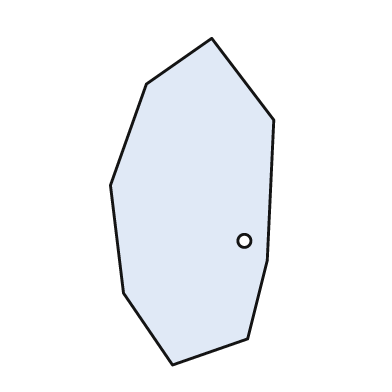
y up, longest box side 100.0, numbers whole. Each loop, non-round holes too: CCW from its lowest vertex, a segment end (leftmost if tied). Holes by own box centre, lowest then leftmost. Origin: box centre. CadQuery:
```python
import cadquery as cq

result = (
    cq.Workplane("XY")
    .moveTo(-6.0, -50.0)
    .lineTo(17.0, -42.0)
    .lineTo(23.0, -18.0)
    .lineTo(25.0, 25.0)
    .lineTo(6.0, 50.0)
    .lineTo(-14.0, 36.0)
    .lineTo(-25.0, 5.0)
    .lineTo(-21.0, -28.0)
    .close()
    .moveTo(16.0, -12.0)
    .circle(2.0)
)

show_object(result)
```